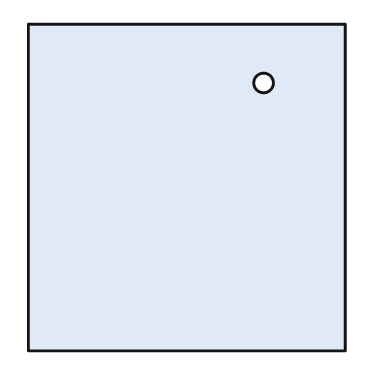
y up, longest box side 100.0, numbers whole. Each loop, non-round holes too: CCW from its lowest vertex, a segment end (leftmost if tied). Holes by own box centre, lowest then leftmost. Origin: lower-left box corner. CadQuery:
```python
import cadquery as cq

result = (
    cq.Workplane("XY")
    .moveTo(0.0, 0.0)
    .lineTo(97.0, 0.0)
    .lineTo(97.0, 100.0)
    .lineTo(0.0, 100.0)
    .close()
    .moveTo(72.0, 82.0)
    .circle(3.0)
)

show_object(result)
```